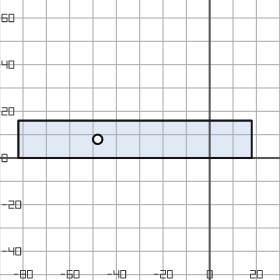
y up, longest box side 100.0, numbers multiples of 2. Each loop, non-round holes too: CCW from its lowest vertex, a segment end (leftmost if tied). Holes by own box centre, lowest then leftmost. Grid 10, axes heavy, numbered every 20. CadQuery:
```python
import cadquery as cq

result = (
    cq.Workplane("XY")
    .moveTo(-82.0, 0.0)
    .lineTo(18.0, 0.0)
    .lineTo(18.0, 16.0)
    .lineTo(-82.0, 16.0)
    .close()
    .moveTo(-48.0, 8.0)
    .circle(2.0)
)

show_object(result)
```